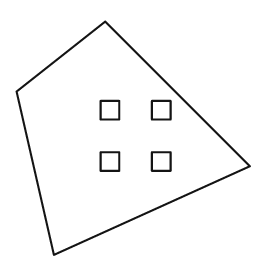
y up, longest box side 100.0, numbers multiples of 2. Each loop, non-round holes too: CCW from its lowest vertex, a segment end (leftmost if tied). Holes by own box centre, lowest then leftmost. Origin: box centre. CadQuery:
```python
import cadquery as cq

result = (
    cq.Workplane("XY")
    .moveTo(-34.0, -50.0)
    .lineTo(50.0, -12.0)
    .lineTo(-12.0, 50.0)
    .lineTo(-50.0, 20.0)
    .close()
    .moveTo(-14.0, -14.0)
    .lineTo(-6.0, -14.0)
    .lineTo(-6.0, -6.0)
    .lineTo(-14.0, -6.0)
    .close()
    .moveTo(8.0, -14.0)
    .lineTo(16.0, -14.0)
    .lineTo(16.0, -6.0)
    .lineTo(8.0, -6.0)
    .close()
    .moveTo(-14.0, 8.0)
    .lineTo(-6.0, 8.0)
    .lineTo(-6.0, 16.0)
    .lineTo(-14.0, 16.0)
    .close()
    .moveTo(8.0, 8.0)
    .lineTo(16.0, 8.0)
    .lineTo(16.0, 16.0)
    .lineTo(8.0, 16.0)
    .close()
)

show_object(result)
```